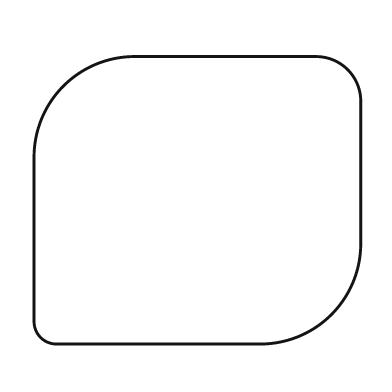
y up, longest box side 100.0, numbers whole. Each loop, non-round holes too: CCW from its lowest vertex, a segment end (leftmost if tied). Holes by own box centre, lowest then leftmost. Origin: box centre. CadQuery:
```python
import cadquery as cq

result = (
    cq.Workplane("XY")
    .moveTo(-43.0, -44.0)
    .lineTo(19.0, -44.0)
    .threePointArc((41.0, -35.0), (50.0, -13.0))
    .lineTo(50.0, 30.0)
    .threePointArc((46.0, 40.0), (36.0, 44.0))
    .lineTo(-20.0, 44.0)
    .threePointArc((-41.0, 35.0), (-50.0, 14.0))
    .lineTo(-50.0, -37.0)
    .threePointArc((-48.0, -42.0), (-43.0, -44.0))
    .close()
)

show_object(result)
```